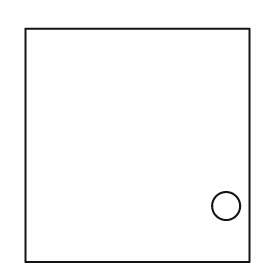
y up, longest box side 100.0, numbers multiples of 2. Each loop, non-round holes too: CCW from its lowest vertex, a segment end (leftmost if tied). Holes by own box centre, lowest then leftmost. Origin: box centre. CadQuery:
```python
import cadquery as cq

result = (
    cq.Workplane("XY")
    .moveTo(-48.0, -50.0)
    .lineTo(48.0, -50.0)
    .lineTo(48.0, 50.0)
    .lineTo(-48.0, 50.0)
    .close()
    .moveTo(38.0, -26.0)
    .circle(6.0)
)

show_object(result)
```